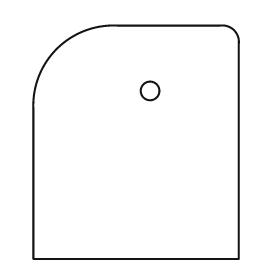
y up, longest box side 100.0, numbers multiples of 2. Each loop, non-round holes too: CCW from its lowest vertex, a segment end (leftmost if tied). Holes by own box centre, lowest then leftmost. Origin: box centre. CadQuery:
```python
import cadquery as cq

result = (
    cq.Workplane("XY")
    .moveTo(-44.0, -50.0)
    .lineTo(44.0, -50.0)
    .lineTo(44.0, 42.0)
    .threePointArc((42.0, 48.0), (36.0, 50.0))
    .lineTo(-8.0, 50.0)
    .threePointArc((-34.0, 40.0), (-44.0, 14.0))
    .close()
    .moveTo(6.0, 22.0)
    .circle(4.0)
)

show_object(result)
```